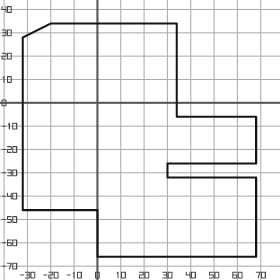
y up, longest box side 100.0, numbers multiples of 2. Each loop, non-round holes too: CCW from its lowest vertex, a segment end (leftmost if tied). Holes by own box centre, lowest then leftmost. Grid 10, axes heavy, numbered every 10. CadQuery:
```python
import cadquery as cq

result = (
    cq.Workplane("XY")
    .moveTo(0.0, -66.0)
    .lineTo(68.0, -66.0)
    .lineTo(68.0, -32.0)
    .lineTo(30.0, -32.0)
    .lineTo(30.0, -26.0)
    .lineTo(68.0, -26.0)
    .lineTo(68.0, -6.0)
    .lineTo(34.0, -6.0)
    .lineTo(34.0, 34.0)
    .lineTo(-20.0, 34.0)
    .lineTo(-32.0, 28.0)
    .lineTo(-32.0, -46.0)
    .lineTo(0.0, -46.0)
    .close()
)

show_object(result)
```